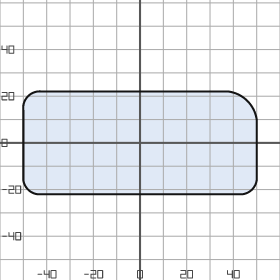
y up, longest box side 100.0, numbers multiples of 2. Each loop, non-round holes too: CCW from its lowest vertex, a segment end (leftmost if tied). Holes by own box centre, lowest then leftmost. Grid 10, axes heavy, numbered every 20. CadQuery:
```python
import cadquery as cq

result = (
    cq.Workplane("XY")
    .moveTo(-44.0, -22.0)
    .lineTo(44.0, -22.0)
    .threePointArc((48.0, -20.0), (50.0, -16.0))
    .lineTo(50.0, 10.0)
    .threePointArc((46.0, 18.0), (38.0, 22.0))
    .lineTo(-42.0, 22.0)
    .threePointArc((-48.0, 20.0), (-50.0, 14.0))
    .lineTo(-50.0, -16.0)
    .threePointArc((-48.0, -20.0), (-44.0, -22.0))
    .close()
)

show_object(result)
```